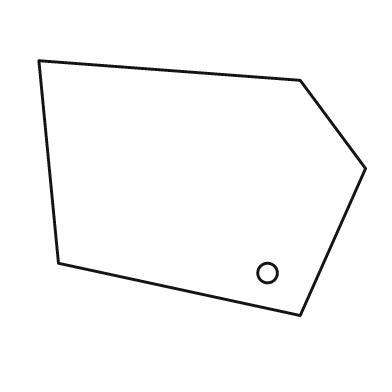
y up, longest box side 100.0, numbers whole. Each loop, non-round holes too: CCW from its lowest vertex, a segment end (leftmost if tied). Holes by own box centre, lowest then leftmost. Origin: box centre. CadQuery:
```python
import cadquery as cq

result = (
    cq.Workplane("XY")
    .moveTo(30.0, -39.0)
    .lineTo(50.0, 6.0)
    .lineTo(30.0, 33.0)
    .lineTo(-50.0, 39.0)
    .lineTo(-44.0, -23.0)
    .close()
    .moveTo(20.0, -26.0)
    .circle(3.0)
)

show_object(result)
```